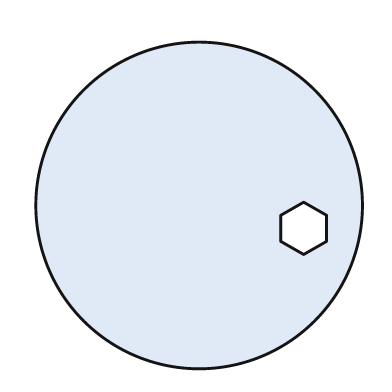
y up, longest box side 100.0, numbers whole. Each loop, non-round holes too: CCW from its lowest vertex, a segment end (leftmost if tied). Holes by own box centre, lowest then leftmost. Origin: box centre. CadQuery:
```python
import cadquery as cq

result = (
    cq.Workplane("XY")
    .moveTo(0.0, 0.0)
    .circle(50.0)
    .moveTo(32.0, -15.0)
    .lineTo(39.0, -11.0)
    .lineTo(39.0, -3.0)
    .lineTo(32.0, 1.0)
    .lineTo(25.0, -3.0)
    .lineTo(25.0, -11.0)
    .close()
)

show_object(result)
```